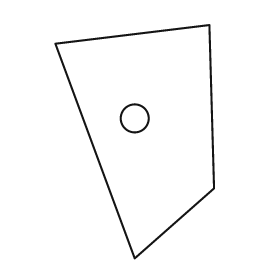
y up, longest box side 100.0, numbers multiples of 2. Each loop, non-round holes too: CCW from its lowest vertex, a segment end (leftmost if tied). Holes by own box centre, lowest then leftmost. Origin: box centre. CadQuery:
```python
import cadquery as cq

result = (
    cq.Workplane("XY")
    .moveTo(0.0, -50.0)
    .lineTo(34.0, -20.0)
    .lineTo(32.0, 50.0)
    .lineTo(-34.0, 42.0)
    .close()
    .moveTo(0.0, 10.0)
    .circle(6.0)
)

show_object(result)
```